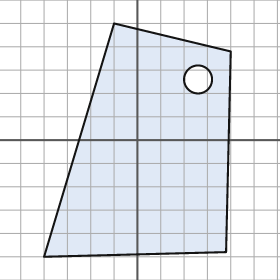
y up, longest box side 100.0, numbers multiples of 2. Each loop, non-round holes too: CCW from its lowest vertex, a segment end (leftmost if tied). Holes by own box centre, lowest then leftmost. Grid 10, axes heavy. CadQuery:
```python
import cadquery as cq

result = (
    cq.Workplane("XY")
    .moveTo(-40.0, -50.0)
    .lineTo(38.0, -48.0)
    .lineTo(40.0, 38.0)
    .lineTo(-10.0, 50.0)
    .close()
    .moveTo(26.0, 26.0)
    .circle(6.0)
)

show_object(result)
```